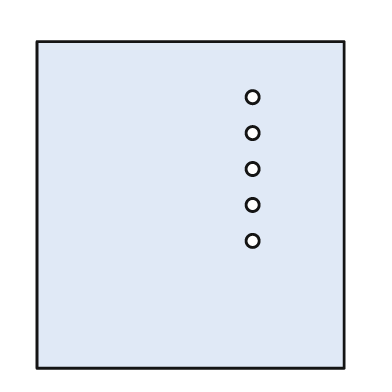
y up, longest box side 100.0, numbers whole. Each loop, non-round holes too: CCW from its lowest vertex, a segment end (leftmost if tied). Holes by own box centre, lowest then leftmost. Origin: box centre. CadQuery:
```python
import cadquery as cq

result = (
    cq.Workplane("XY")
    .moveTo(-47.0, -50.0)
    .lineTo(47.0, -50.0)
    .lineTo(47.0, 50.0)
    .lineTo(-47.0, 50.0)
    .close()
    .moveTo(19.0, -11.0)
    .circle(2.0)
    .moveTo(19.0, 0.0)
    .circle(2.0)
    .moveTo(19.0, 11.0)
    .circle(2.0)
    .moveTo(19.0, 22.0)
    .circle(2.0)
    .moveTo(19.0, 33.0)
    .circle(2.0)
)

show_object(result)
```